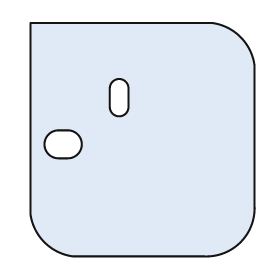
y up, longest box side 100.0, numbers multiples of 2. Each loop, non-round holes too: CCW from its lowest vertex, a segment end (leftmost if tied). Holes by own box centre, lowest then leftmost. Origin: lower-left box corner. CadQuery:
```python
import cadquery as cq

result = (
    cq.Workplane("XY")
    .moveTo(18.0, 0.0)
    .lineTo(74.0, 0.0)
    .threePointArc((90.0, 6.0), (96.0, 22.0))
    .lineTo(96.0, 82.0)
    .threePointArc((90.0, 94.0), (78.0, 100.0))
    .lineTo(0.0, 100.0)
    .lineTo(0.0, 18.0)
    .threePointArc((6.0, 6.0), (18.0, 0.0))
    .close()
    .moveTo(12.0, 42.0)
    .lineTo(16.0, 42.0)
    .threePointArc((22.0, 48.0), (16.0, 54.0))
    .lineTo(12.0, 54.0)
    .threePointArc((6.0, 48.0), (12.0, 42.0))
    .close()
    .moveTo(34.0, 64.0)
    .threePointArc((38.0, 60.0), (42.0, 64.0))
    .lineTo(42.0, 72.0)
    .threePointArc((38.0, 76.0), (34.0, 72.0))
    .close()
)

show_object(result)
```